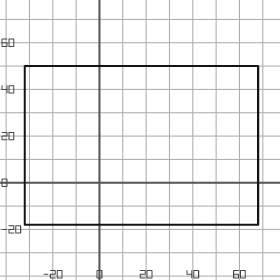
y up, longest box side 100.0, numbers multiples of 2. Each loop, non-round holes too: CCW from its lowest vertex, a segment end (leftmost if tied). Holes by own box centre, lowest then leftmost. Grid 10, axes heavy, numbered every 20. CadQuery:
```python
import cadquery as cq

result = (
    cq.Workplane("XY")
    .moveTo(-32.0, -18.0)
    .lineTo(68.0, -18.0)
    .lineTo(68.0, 50.0)
    .lineTo(-32.0, 50.0)
    .close()
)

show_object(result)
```